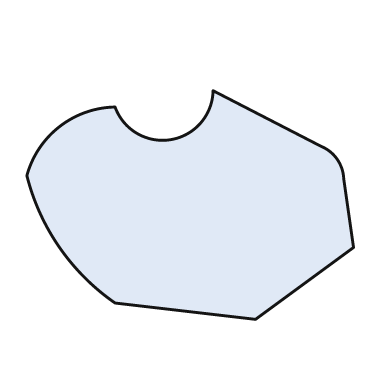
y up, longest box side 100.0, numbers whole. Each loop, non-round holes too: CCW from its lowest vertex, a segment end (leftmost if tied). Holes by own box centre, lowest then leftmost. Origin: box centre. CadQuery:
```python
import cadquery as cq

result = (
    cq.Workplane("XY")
    .moveTo(20.0, -35.0)
    .lineTo(50.0, -13.0)
    .lineTo(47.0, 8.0)
    .threePointArc((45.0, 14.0), (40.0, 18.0))
    .lineTo(7.0, 35.0)
    .threePointArc((-6.0, 20.0), (-23.0, 30.0))
    .threePointArc((-40.0, 24.0), (-50.0, 9.0))
    .threePointArc((-40.0, -13.0), (-23.0, -30.0))
    .close()
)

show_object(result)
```